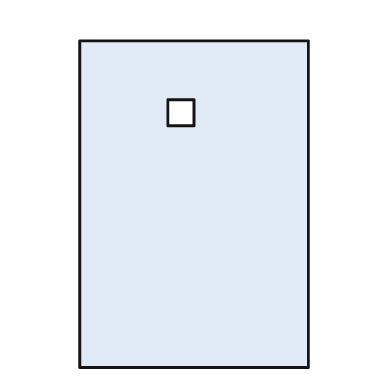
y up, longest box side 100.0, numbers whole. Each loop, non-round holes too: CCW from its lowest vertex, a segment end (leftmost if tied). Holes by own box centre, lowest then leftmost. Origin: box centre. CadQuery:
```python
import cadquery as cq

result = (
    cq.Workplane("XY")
    .moveTo(-35.0, -50.0)
    .lineTo(35.0, -50.0)
    .lineTo(35.0, 50.0)
    .lineTo(-35.0, 50.0)
    .close()
    .moveTo(-8.0, 24.0)
    .lineTo(0.0, 24.0)
    .lineTo(0.0, 32.0)
    .lineTo(-8.0, 32.0)
    .close()
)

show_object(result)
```